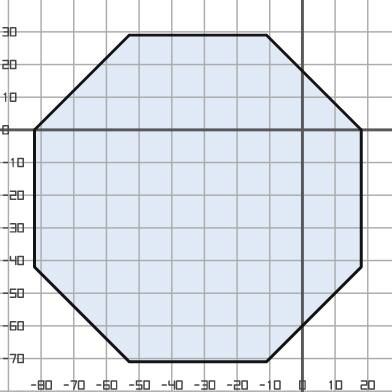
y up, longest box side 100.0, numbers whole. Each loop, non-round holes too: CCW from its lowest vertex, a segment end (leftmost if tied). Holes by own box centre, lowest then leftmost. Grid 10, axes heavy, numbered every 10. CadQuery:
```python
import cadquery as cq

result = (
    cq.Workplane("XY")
    .moveTo(-53.0, -71.0)
    .lineTo(-11.0, -71.0)
    .lineTo(18.0, -42.0)
    .lineTo(18.0, 0.0)
    .lineTo(-11.0, 29.0)
    .lineTo(-53.0, 29.0)
    .lineTo(-82.0, 0.0)
    .lineTo(-82.0, -42.0)
    .close()
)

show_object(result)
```